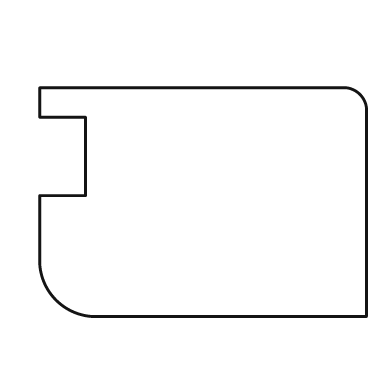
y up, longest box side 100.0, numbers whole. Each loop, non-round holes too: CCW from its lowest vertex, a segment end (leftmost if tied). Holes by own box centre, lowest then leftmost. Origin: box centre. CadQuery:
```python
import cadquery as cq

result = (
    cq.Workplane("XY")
    .moveTo(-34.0, -35.0)
    .lineTo(50.0, -35.0)
    .lineTo(50.0, 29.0)
    .threePointArc((48.0, 33.0), (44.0, 35.0))
    .lineTo(-50.0, 35.0)
    .lineTo(-50.0, 26.0)
    .lineTo(-36.0, 26.0)
    .lineTo(-36.0, 2.0)
    .lineTo(-50.0, 2.0)
    .lineTo(-50.0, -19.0)
    .threePointArc((-45.0, -30.0), (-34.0, -35.0))
    .close()
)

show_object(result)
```